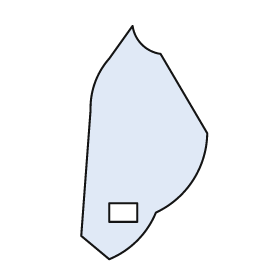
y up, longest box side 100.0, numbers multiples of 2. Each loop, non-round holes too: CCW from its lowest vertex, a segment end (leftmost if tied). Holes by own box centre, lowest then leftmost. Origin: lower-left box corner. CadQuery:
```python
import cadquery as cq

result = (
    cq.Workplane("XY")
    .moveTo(12.0, 0.0)
    .threePointArc((24.0, 8.0), (32.0, 20.0))
    .threePointArc((48.0, 34.0), (54.0, 54.0))
    .lineTo(34.0, 88.0)
    .threePointArc((26.0, 92.0), (22.0, 100.0))
    .lineTo(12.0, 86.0)
    .threePointArc((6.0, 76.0), (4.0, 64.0))
    .lineTo(0.0, 10.0)
    .close()
    .moveTo(12.0, 16.0)
    .lineTo(24.0, 16.0)
    .lineTo(24.0, 24.0)
    .lineTo(12.0, 24.0)
    .close()
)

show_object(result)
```